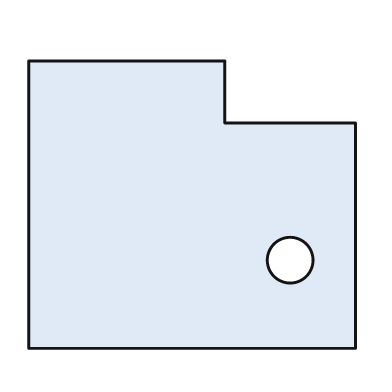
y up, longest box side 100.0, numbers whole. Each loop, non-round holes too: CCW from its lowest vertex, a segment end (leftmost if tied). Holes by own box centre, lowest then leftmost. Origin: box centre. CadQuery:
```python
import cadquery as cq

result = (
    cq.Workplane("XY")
    .moveTo(-50.0, -44.0)
    .lineTo(50.0, -44.0)
    .lineTo(50.0, 25.0)
    .lineTo(10.0, 25.0)
    .lineTo(10.0, 44.0)
    .lineTo(-50.0, 44.0)
    .close()
    .moveTo(30.0, -17.0)
    .circle(7.0)
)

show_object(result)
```